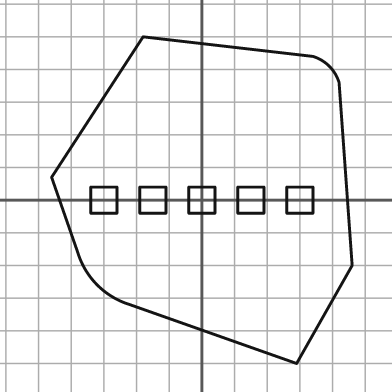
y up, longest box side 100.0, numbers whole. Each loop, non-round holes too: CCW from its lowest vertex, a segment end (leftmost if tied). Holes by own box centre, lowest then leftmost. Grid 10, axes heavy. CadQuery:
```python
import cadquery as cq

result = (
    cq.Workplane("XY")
    .moveTo(29.0, -50.0)
    .lineTo(46.0, -20.0)
    .lineTo(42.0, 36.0)
    .threePointArc((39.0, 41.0), (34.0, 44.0))
    .lineTo(-18.0, 50.0)
    .lineTo(-46.0, 7.0)
    .lineTo(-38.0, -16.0)
    .threePointArc((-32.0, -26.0), (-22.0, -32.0))
    .close()
    .moveTo(-34.0, -4.0)
    .lineTo(-26.0, -4.0)
    .lineTo(-26.0, 4.0)
    .lineTo(-34.0, 4.0)
    .close()
    .moveTo(-19.0, -4.0)
    .lineTo(-11.0, -4.0)
    .lineTo(-11.0, 4.0)
    .lineTo(-19.0, 4.0)
    .close()
    .moveTo(-4.0, -4.0)
    .lineTo(4.0, -4.0)
    .lineTo(4.0, 4.0)
    .lineTo(-4.0, 4.0)
    .close()
    .moveTo(11.0, -4.0)
    .lineTo(19.0, -4.0)
    .lineTo(19.0, 4.0)
    .lineTo(11.0, 4.0)
    .close()
    .moveTo(26.0, -4.0)
    .lineTo(34.0, -4.0)
    .lineTo(34.0, 4.0)
    .lineTo(26.0, 4.0)
    .close()
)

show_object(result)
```